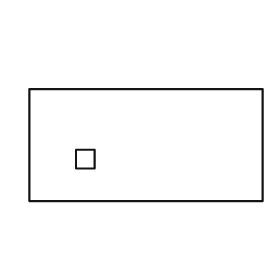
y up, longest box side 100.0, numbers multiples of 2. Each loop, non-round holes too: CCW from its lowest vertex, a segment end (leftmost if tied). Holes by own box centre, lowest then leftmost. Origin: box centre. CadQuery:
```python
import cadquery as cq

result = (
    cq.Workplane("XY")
    .moveTo(-50.0, -24.0)
    .lineTo(50.0, -24.0)
    .lineTo(50.0, 24.0)
    .lineTo(-50.0, 24.0)
    .close()
    .moveTo(-30.0, -10.0)
    .lineTo(-22.0, -10.0)
    .lineTo(-22.0, -2.0)
    .lineTo(-30.0, -2.0)
    .close()
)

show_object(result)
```